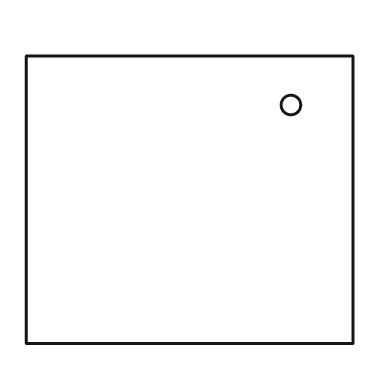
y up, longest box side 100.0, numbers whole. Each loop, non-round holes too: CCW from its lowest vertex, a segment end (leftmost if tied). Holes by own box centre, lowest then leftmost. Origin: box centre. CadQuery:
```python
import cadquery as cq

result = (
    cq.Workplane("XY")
    .moveTo(-50.0, -44.0)
    .lineTo(50.0, -44.0)
    .lineTo(50.0, 44.0)
    .lineTo(-50.0, 44.0)
    .close()
    .moveTo(31.0, 29.0)
    .circle(3.0)
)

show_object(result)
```